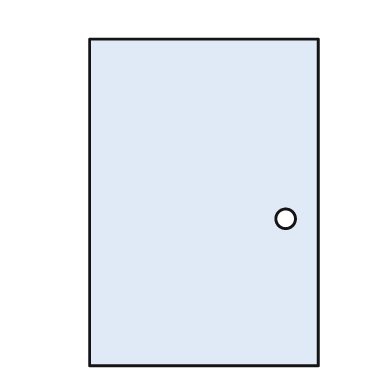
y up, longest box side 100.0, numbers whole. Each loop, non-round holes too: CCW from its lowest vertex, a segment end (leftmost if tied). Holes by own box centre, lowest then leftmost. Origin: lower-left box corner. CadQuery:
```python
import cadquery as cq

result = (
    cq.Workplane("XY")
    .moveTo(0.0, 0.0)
    .lineTo(70.0, 0.0)
    .lineTo(70.0, 100.0)
    .lineTo(0.0, 100.0)
    .close()
    .moveTo(60.0, 45.0)
    .circle(3.0)
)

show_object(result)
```